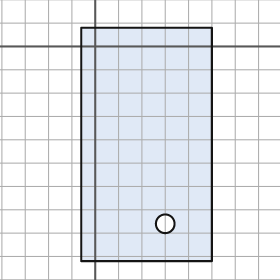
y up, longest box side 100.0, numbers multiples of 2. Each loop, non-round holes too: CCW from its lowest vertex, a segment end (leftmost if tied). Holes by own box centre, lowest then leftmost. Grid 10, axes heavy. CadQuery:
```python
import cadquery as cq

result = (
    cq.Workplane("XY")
    .moveTo(-6.0, -92.0)
    .lineTo(50.0, -92.0)
    .lineTo(50.0, 8.0)
    .lineTo(-6.0, 8.0)
    .close()
    .moveTo(30.0, -76.0)
    .circle(4.0)
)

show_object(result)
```